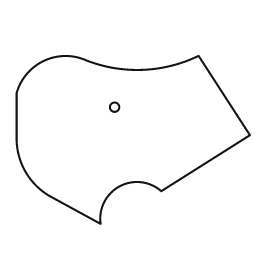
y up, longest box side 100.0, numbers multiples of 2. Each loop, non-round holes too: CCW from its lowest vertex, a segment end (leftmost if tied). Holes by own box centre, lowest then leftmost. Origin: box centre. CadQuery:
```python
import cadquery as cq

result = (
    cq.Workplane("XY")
    .moveTo(-14.0, -36.0)
    .threePointArc((-6.0, -20.0), (12.0, -22.0))
    .lineTo(50.0, 2.0)
    .lineTo(28.0, 36.0)
    .threePointArc((4.0, 30.0), (-20.0, 34.0))
    .threePointArc((-38.0, 34.0), (-50.0, 20.0))
    .lineTo(-50.0, 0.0)
    .threePointArc((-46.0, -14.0), (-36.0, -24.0))
    .close()
    .moveTo(-8.0, 14.0)
    .circle(2.0)
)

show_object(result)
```